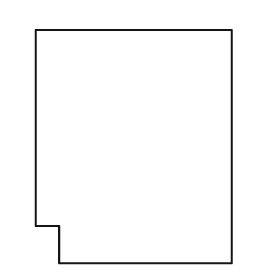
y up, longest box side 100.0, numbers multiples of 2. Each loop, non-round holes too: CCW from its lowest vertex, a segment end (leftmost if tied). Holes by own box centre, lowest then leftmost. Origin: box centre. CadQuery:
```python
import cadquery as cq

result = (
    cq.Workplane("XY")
    .moveTo(-32.0, -50.0)
    .lineTo(42.0, -50.0)
    .lineTo(42.0, 50.0)
    .lineTo(-42.0, 50.0)
    .lineTo(-42.0, -34.0)
    .lineTo(-32.0, -34.0)
    .close()
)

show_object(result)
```